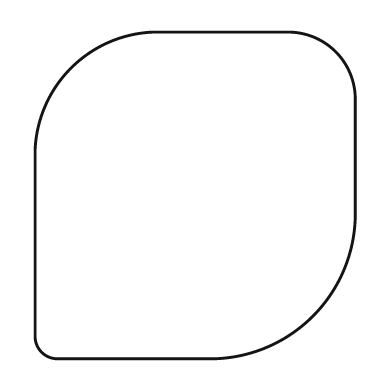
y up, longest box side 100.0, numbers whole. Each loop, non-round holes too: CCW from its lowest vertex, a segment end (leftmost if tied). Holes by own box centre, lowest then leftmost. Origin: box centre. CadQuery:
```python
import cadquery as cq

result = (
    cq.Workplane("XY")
    .moveTo(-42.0, -50.0)
    .lineTo(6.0, -50.0)
    .threePointArc((36.0, -37.0), (49.0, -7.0))
    .lineTo(49.0, 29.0)
    .threePointArc((43.0, 44.0), (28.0, 50.0))
    .lineTo(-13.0, 50.0)
    .threePointArc((-38.0, 39.0), (-49.0, 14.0))
    .lineTo(-49.0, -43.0)
    .threePointArc((-47.0, -48.0), (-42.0, -50.0))
    .close()
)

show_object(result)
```